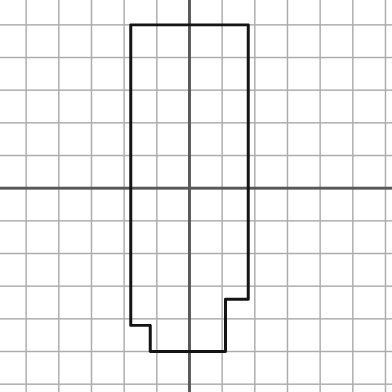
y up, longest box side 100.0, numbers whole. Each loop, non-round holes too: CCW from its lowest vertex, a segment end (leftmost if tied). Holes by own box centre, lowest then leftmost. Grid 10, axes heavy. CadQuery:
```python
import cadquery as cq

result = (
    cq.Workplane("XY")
    .moveTo(-12.0, -50.0)
    .lineTo(11.0, -50.0)
    .lineTo(11.0, -34.0)
    .lineTo(18.0, -34.0)
    .lineTo(18.0, 50.0)
    .lineTo(-18.0, 50.0)
    .lineTo(-18.0, -42.0)
    .lineTo(-12.0, -42.0)
    .close()
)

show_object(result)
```